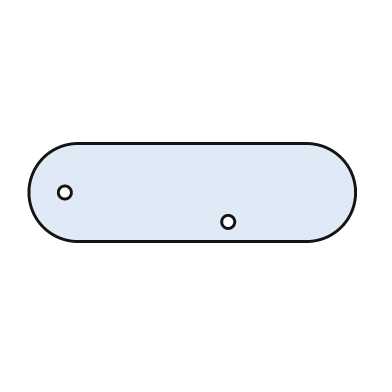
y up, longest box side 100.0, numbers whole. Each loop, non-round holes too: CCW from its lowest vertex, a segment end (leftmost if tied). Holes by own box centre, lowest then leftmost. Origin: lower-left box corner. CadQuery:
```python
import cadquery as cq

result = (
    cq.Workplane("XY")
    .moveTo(15.0, 0.0)
    .lineTo(85.0, 0.0)
    .threePointArc((100.0, 15.0), (85.0, 30.0))
    .lineTo(15.0, 30.0)
    .threePointArc((0.0, 15.0), (15.0, 0.0))
    .close()
    .moveTo(61.0, 6.0)
    .circle(2.0)
    .moveTo(11.0, 15.0)
    .circle(2.0)
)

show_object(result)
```